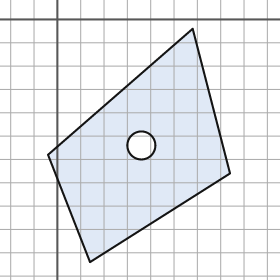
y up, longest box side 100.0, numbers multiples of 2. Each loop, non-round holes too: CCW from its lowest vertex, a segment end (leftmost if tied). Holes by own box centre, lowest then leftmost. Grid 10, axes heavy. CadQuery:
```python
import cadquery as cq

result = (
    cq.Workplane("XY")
    .moveTo(14.0, -104.0)
    .lineTo(74.0, -66.0)
    .lineTo(58.0, -4.0)
    .lineTo(-4.0, -58.0)
    .close()
    .moveTo(36.0, -54.0)
    .circle(6.0)
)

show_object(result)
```